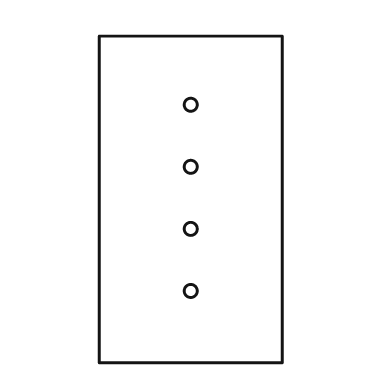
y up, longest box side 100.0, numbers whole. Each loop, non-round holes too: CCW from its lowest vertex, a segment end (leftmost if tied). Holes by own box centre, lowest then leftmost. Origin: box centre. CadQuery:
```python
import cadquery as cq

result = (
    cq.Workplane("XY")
    .moveTo(-28.0, -50.0)
    .lineTo(28.0, -50.0)
    .lineTo(28.0, 50.0)
    .lineTo(-28.0, 50.0)
    .close()
    .moveTo(0.0, -28.0)
    .circle(2.0)
    .moveTo(0.0, -9.0)
    .circle(2.0)
    .moveTo(0.0, 10.0)
    .circle(2.0)
    .moveTo(0.0, 29.0)
    .circle(2.0)
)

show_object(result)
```